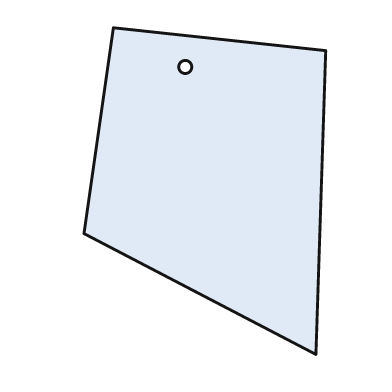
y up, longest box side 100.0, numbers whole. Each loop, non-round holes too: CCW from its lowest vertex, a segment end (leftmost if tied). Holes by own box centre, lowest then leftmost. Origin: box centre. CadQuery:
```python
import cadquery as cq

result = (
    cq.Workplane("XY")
    .moveTo(34.0, -50.0)
    .lineTo(37.0, 43.0)
    .lineTo(-28.0, 50.0)
    .lineTo(-37.0, -13.0)
    .close()
    .moveTo(-6.0, 38.0)
    .circle(2.0)
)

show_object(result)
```